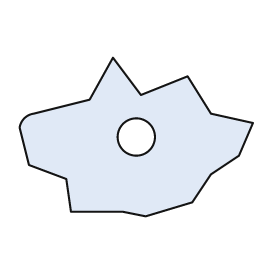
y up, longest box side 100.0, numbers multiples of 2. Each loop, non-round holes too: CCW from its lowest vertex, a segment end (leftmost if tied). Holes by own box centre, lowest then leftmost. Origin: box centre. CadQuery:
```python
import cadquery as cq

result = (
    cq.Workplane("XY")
    .moveTo(4.0, -34.0)
    .lineTo(24.0, -28.0)
    .lineTo(32.0, -16.0)
    .lineTo(44.0, -8.0)
    .lineTo(50.0, 6.0)
    .lineTo(32.0, 10.0)
    .lineTo(22.0, 26.0)
    .lineTo(2.0, 18.0)
    .lineTo(-10.0, 34.0)
    .lineTo(-20.0, 16.0)
    .lineTo(-44.0, 10.0)
    .threePointArc((-48.0, 8.0), (-50.0, 4.0))
    .lineTo(-46.0, -12.0)
    .lineTo(-30.0, -18.0)
    .lineTo(-28.0, -32.0)
    .lineTo(-6.0, -32.0)
    .close()
    .moveTo(0.0, 0.0)
    .circle(8.0)
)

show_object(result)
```